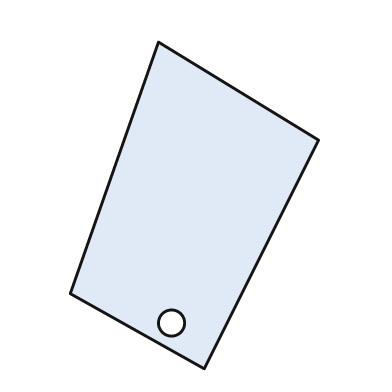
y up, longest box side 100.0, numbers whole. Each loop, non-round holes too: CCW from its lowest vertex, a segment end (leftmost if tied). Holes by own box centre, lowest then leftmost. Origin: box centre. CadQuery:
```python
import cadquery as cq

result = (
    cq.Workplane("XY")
    .moveTo(3.0, -50.0)
    .lineTo(38.0, 20.0)
    .lineTo(-11.0, 50.0)
    .lineTo(-38.0, -27.0)
    .close()
    .moveTo(-7.0, -36.0)
    .circle(4.0)
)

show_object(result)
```